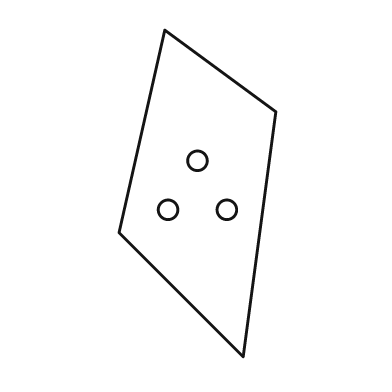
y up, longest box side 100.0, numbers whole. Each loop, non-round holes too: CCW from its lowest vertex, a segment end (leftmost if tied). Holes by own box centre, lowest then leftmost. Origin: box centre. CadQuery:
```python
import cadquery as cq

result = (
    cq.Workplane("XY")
    .moveTo(14.0, -50.0)
    .lineTo(24.0, 25.0)
    .lineTo(-10.0, 50.0)
    .lineTo(-24.0, -12.0)
    .close()
    .moveTo(-9.0, -5.0)
    .circle(3.0)
    .moveTo(9.0, -5.0)
    .circle(3.0)
    .moveTo(0.0, 10.0)
    .circle(3.0)
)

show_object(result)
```